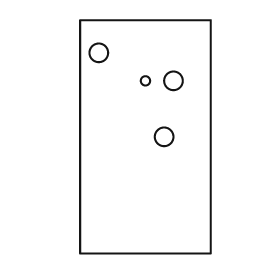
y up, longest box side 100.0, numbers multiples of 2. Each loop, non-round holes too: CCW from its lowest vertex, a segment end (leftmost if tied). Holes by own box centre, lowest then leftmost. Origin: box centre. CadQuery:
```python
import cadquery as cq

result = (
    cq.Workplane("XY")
    .moveTo(-28.0, -50.0)
    .lineTo(28.0, -50.0)
    .lineTo(28.0, 50.0)
    .lineTo(-28.0, 50.0)
    .close()
    .moveTo(8.0, 0.0)
    .circle(4.0)
    .moveTo(0.0, 24.0)
    .circle(2.0)
    .moveTo(12.0, 24.0)
    .circle(4.0)
    .moveTo(-20.0, 36.0)
    .circle(4.0)
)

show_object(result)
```